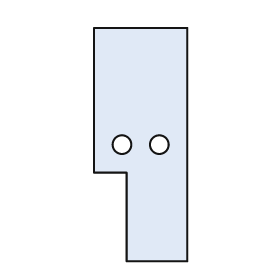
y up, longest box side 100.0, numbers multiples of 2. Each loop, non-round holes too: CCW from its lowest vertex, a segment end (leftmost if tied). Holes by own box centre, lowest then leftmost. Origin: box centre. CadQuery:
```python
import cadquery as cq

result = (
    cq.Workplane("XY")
    .moveTo(-6.0, -50.0)
    .lineTo(20.0, -50.0)
    .lineTo(20.0, 50.0)
    .lineTo(-20.0, 50.0)
    .lineTo(-20.0, -12.0)
    .lineTo(-6.0, -12.0)
    .close()
    .moveTo(-8.0, 0.0)
    .circle(4.0)
    .moveTo(8.0, 0.0)
    .circle(4.0)
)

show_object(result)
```